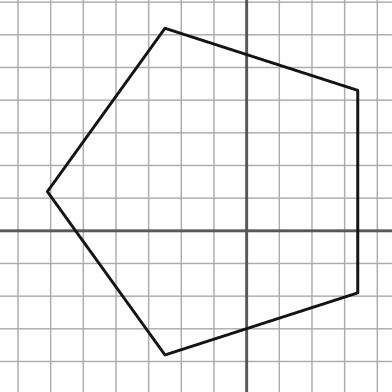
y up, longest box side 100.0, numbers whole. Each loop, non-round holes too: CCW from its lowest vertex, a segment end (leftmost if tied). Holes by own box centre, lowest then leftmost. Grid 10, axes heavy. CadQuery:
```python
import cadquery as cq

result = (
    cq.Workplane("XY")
    .moveTo(-25.0, -38.0)
    .lineTo(34.0, -19.0)
    .lineTo(34.0, 43.0)
    .lineTo(-25.0, 62.0)
    .lineTo(-61.0, 12.0)
    .close()
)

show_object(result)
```